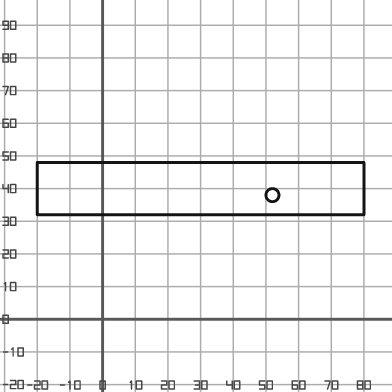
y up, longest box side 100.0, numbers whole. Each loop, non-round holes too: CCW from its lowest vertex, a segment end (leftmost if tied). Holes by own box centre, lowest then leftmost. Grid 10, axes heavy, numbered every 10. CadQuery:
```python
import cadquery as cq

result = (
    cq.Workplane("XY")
    .moveTo(-20.0, 32.0)
    .lineTo(80.0, 32.0)
    .lineTo(80.0, 48.0)
    .lineTo(-20.0, 48.0)
    .close()
    .moveTo(52.0, 38.0)
    .circle(2.0)
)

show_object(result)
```